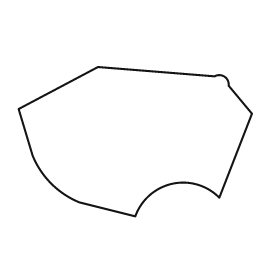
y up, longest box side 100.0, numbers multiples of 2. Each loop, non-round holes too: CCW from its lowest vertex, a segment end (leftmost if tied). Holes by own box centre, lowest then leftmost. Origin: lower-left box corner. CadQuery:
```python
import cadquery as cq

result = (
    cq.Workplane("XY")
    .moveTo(50.0, 0.0)
    .threePointArc((66.0, 14.0), (86.0, 8.0))
    .lineTo(100.0, 44.0)
    .lineTo(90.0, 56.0)
    .threePointArc((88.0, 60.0), (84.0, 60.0))
    .lineTo(34.0, 64.0)
    .lineTo(0.0, 46.0)
    .lineTo(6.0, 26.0)
    .threePointArc((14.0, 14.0), (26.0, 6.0))
    .close()
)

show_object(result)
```